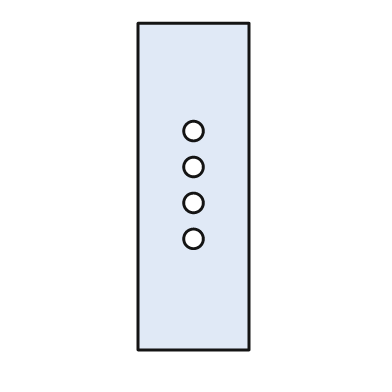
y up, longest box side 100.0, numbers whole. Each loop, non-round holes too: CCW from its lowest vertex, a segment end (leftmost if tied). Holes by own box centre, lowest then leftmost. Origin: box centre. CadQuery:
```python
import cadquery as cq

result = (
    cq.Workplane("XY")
    .moveTo(-17.0, -50.0)
    .lineTo(17.0, -50.0)
    .lineTo(17.0, 50.0)
    .lineTo(-17.0, 50.0)
    .close()
    .moveTo(0.0, -16.0)
    .circle(3.0)
    .moveTo(0.0, -5.0)
    .circle(3.0)
    .moveTo(0.0, 6.0)
    .circle(3.0)
    .moveTo(0.0, 17.0)
    .circle(3.0)
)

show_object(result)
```